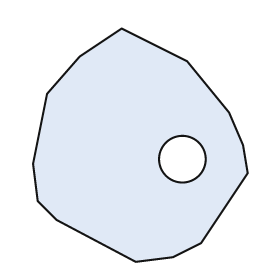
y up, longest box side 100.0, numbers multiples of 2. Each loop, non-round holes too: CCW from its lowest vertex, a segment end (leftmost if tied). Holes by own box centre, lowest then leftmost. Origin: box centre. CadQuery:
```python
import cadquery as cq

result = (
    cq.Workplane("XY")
    .moveTo(-2.0, -50.0)
    .lineTo(14.0, -48.0)
    .lineTo(26.0, -42.0)
    .lineTo(46.0, -12.0)
    .lineTo(44.0, 0.0)
    .lineTo(38.0, 14.0)
    .lineTo(20.0, 36.0)
    .lineTo(-8.0, 50.0)
    .lineTo(-26.0, 38.0)
    .lineTo(-40.0, 22.0)
    .lineTo(-46.0, -8.0)
    .lineTo(-44.0, -24.0)
    .lineTo(-36.0, -32.0)
    .close()
    .moveTo(18.0, -6.0)
    .circle(10.0)
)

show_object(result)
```